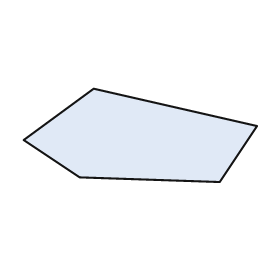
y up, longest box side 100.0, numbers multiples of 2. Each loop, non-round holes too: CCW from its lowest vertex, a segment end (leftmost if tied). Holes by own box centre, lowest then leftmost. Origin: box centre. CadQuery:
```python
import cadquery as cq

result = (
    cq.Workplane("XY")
    .moveTo(34.0, -20.0)
    .lineTo(50.0, 4.0)
    .lineTo(-20.0, 20.0)
    .lineTo(-50.0, -2.0)
    .lineTo(-26.0, -18.0)
    .close()
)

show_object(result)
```